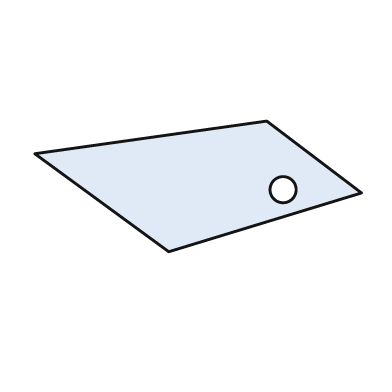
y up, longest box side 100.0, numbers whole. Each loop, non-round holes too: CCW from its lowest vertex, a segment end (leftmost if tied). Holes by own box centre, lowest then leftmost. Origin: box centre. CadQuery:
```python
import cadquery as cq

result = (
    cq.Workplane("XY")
    .moveTo(-9.0, -20.0)
    .lineTo(50.0, -2.0)
    .lineTo(21.0, 20.0)
    .lineTo(-50.0, 10.0)
    .close()
    .moveTo(26.0, -1.0)
    .circle(4.0)
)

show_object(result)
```